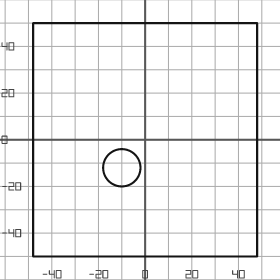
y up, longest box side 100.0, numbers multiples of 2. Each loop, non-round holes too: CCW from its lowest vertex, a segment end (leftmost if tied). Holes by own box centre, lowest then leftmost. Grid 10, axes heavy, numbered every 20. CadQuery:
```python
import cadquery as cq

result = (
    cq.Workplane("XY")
    .moveTo(-48.0, -50.0)
    .lineTo(48.0, -50.0)
    .lineTo(48.0, 50.0)
    .lineTo(-48.0, 50.0)
    .close()
    .moveTo(-10.0, -12.0)
    .circle(8.0)
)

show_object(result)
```